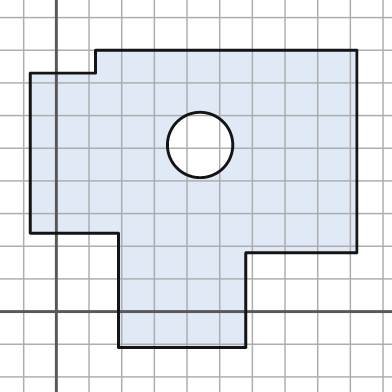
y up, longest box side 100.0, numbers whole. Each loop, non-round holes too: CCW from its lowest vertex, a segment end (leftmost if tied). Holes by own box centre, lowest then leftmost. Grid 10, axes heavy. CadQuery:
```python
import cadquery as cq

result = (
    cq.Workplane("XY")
    .moveTo(19.0, -11.0)
    .lineTo(58.0, -11.0)
    .lineTo(58.0, 18.0)
    .lineTo(92.0, 18.0)
    .lineTo(92.0, 80.0)
    .lineTo(12.0, 80.0)
    .lineTo(12.0, 73.0)
    .lineTo(-8.0, 73.0)
    .lineTo(-8.0, 24.0)
    .lineTo(19.0, 24.0)
    .close()
    .moveTo(44.0, 51.0)
    .circle(10.0)
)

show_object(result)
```